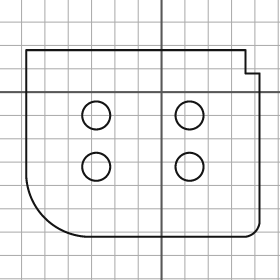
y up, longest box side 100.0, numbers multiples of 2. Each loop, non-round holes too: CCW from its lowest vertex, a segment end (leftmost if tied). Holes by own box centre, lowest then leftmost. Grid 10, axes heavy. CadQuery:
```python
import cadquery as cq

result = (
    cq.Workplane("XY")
    .moveTo(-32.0, -62.0)
    .lineTo(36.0, -62.0)
    .threePointArc((40.0, -60.0), (42.0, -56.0))
    .lineTo(42.0, 8.0)
    .lineTo(36.0, 8.0)
    .lineTo(36.0, 18.0)
    .lineTo(-58.0, 18.0)
    .lineTo(-58.0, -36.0)
    .threePointArc((-50.0, -54.0), (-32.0, -62.0))
    .close()
    .moveTo(-28.0, -32.0)
    .circle(6.0)
    .moveTo(12.0, -32.0)
    .circle(6.0)
    .moveTo(-28.0, -10.0)
    .circle(6.0)
    .moveTo(12.0, -10.0)
    .circle(6.0)
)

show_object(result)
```